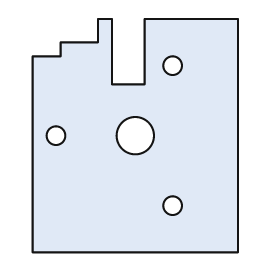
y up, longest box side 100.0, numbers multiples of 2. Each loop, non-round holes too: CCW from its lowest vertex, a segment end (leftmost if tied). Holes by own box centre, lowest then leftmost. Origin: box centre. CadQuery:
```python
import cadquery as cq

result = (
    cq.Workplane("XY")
    .moveTo(-44.0, -50.0)
    .lineTo(44.0, -50.0)
    .lineTo(44.0, 50.0)
    .lineTo(4.0, 50.0)
    .lineTo(4.0, 22.0)
    .lineTo(-10.0, 22.0)
    .lineTo(-10.0, 50.0)
    .lineTo(-16.0, 50.0)
    .lineTo(-16.0, 40.0)
    .lineTo(-32.0, 40.0)
    .lineTo(-32.0, 34.0)
    .lineTo(-44.0, 34.0)
    .close()
    .moveTo(16.0, -30.0)
    .circle(4.0)
    .moveTo(-34.0, 0.0)
    .circle(4.0)
    .moveTo(0.0, 0.0)
    .circle(8.0)
    .moveTo(16.0, 30.0)
    .circle(4.0)
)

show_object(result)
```